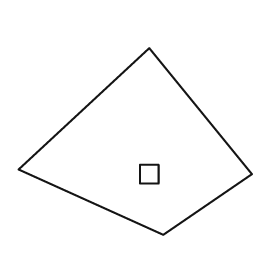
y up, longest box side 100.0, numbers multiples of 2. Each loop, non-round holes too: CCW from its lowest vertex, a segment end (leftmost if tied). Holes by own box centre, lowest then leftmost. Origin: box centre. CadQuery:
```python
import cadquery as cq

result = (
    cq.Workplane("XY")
    .moveTo(12.0, -40.0)
    .lineTo(50.0, -14.0)
    .lineTo(6.0, 40.0)
    .lineTo(-50.0, -12.0)
    .close()
    .moveTo(2.0, -18.0)
    .lineTo(10.0, -18.0)
    .lineTo(10.0, -10.0)
    .lineTo(2.0, -10.0)
    .close()
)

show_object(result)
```